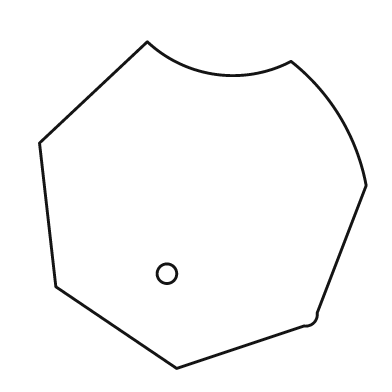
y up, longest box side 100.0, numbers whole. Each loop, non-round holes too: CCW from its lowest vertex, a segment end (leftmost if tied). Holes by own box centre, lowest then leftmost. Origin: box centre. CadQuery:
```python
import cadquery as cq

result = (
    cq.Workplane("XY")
    .moveTo(-8.0, -50.0)
    .lineTo(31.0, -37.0)
    .threePointArc((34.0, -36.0), (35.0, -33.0))
    .lineTo(50.0, 6.0)
    .threePointArc((42.0, 27.0), (27.0, 44.0))
    .threePointArc((4.0, 40.0), (-17.0, 50.0))
    .lineTo(-50.0, 19.0)
    .lineTo(-45.0, -25.0)
    .close()
    .moveTo(-11.0, -21.0)
    .circle(3.0)
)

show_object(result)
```